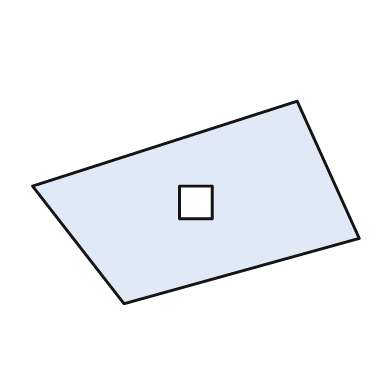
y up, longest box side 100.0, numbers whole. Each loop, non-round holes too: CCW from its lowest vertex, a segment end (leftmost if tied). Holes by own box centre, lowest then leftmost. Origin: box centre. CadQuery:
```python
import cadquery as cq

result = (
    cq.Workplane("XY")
    .moveTo(-22.0, -31.0)
    .lineTo(50.0, -11.0)
    .lineTo(31.0, 31.0)
    .lineTo(-50.0, 5.0)
    .close()
    .moveTo(-5.0, -5.0)
    .lineTo(5.0, -5.0)
    .lineTo(5.0, 5.0)
    .lineTo(-5.0, 5.0)
    .close()
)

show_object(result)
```